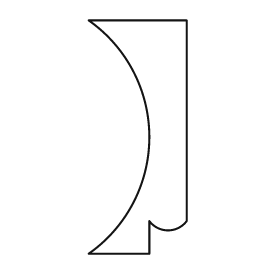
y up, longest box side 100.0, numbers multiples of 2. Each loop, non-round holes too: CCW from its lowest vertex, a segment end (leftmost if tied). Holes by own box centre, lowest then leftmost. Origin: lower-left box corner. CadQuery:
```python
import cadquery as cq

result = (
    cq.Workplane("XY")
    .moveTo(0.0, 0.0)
    .lineTo(26.0, 0.0)
    .lineTo(26.0, 14.0)
    .threePointArc((34.0, 10.0), (42.0, 14.0))
    .lineTo(42.0, 100.0)
    .lineTo(0.0, 100.0)
    .threePointArc((26.0, 50.0), (0.0, 0.0))
    .close()
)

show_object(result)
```